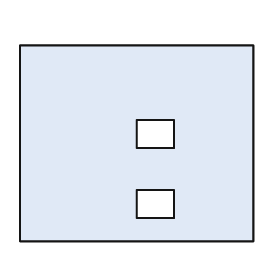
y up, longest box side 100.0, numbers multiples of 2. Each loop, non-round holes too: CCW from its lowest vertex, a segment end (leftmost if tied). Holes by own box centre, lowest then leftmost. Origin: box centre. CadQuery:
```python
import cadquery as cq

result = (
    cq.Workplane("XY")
    .moveTo(-50.0, -42.0)
    .lineTo(50.0, -42.0)
    .lineTo(50.0, 42.0)
    .lineTo(-50.0, 42.0)
    .close()
    .moveTo(0.0, -32.0)
    .lineTo(16.0, -32.0)
    .lineTo(16.0, -20.0)
    .lineTo(0.0, -20.0)
    .close()
    .moveTo(0.0, -2.0)
    .lineTo(16.0, -2.0)
    .lineTo(16.0, 10.0)
    .lineTo(0.0, 10.0)
    .close()
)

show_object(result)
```